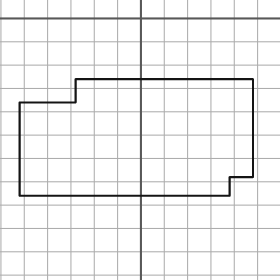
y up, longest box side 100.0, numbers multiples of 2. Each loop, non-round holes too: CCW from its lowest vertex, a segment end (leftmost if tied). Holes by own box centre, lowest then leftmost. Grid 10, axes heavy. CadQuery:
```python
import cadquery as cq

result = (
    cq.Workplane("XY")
    .moveTo(-52.0, -76.0)
    .lineTo(38.0, -76.0)
    .lineTo(38.0, -68.0)
    .lineTo(48.0, -68.0)
    .lineTo(48.0, -26.0)
    .lineTo(-28.0, -26.0)
    .lineTo(-28.0, -36.0)
    .lineTo(-52.0, -36.0)
    .close()
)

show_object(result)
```